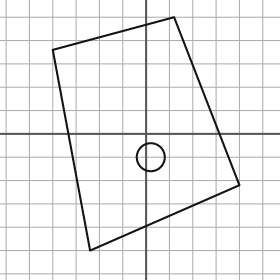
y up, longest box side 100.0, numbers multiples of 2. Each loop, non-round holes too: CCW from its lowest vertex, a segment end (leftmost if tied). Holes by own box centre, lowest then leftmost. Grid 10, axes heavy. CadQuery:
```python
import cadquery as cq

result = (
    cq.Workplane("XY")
    .moveTo(-24.0, -50.0)
    .lineTo(40.0, -22.0)
    .lineTo(12.0, 50.0)
    .lineTo(-40.0, 36.0)
    .close()
    .moveTo(2.0, -10.0)
    .circle(6.0)
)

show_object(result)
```